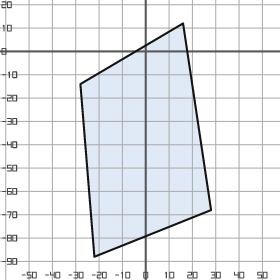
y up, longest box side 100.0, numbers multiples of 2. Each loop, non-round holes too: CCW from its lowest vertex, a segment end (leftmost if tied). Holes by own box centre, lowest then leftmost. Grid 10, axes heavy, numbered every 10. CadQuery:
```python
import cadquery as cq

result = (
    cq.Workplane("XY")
    .moveTo(-22.0, -88.0)
    .lineTo(28.0, -68.0)
    .lineTo(16.0, 12.0)
    .lineTo(-28.0, -14.0)
    .close()
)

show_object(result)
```